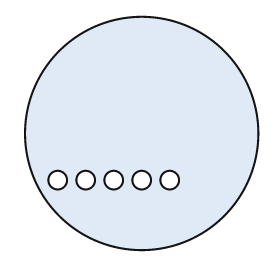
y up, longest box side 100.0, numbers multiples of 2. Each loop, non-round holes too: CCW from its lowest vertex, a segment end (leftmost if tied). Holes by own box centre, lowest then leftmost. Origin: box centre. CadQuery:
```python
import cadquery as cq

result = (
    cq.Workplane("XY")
    .moveTo(0.0, 0.0)
    .circle(50.0)
    .moveTo(-36.0, -20.0)
    .circle(4.0)
    .moveTo(-24.0, -20.0)
    .circle(4.0)
    .moveTo(-12.0, -20.0)
    .circle(4.0)
    .moveTo(0.0, -20.0)
    .circle(4.0)
    .moveTo(12.0, -20.0)
    .circle(4.0)
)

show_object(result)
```